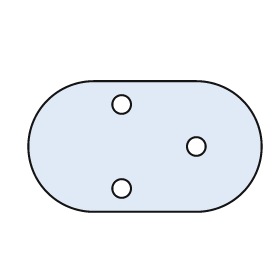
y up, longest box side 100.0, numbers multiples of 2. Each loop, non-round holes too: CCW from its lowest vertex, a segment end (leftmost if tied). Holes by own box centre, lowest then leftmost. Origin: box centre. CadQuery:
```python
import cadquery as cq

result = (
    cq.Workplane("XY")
    .moveTo(-22.0, -28.0)
    .lineTo(22.0, -28.0)
    .threePointArc((50.0, 0.0), (22.0, 28.0))
    .lineTo(-22.0, 28.0)
    .threePointArc((-50.0, 0.0), (-22.0, -28.0))
    .close()
    .moveTo(-10.0, -18.0)
    .circle(4.0)
    .moveTo(22.0, 0.0)
    .circle(4.0)
    .moveTo(-10.0, 18.0)
    .circle(4.0)
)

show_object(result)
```